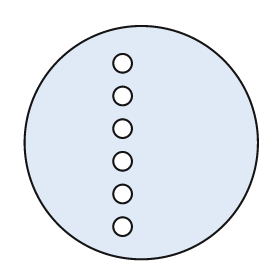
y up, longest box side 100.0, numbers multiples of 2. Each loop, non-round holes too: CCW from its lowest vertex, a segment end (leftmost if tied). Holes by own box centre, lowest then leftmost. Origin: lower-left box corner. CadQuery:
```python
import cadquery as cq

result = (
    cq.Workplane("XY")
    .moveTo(50.0, 50.0)
    .circle(50.0)
    .moveTo(42.0, 14.0)
    .circle(4.0)
    .moveTo(42.0, 28.0)
    .circle(4.0)
    .moveTo(42.0, 42.0)
    .circle(4.0)
    .moveTo(42.0, 56.0)
    .circle(4.0)
    .moveTo(42.0, 70.0)
    .circle(4.0)
    .moveTo(42.0, 84.0)
    .circle(4.0)
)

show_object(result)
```